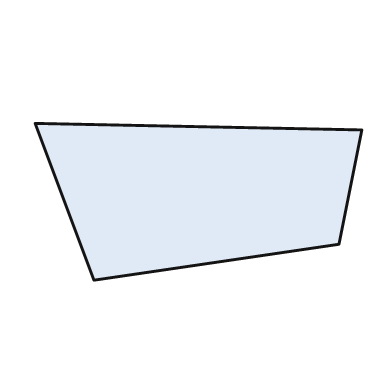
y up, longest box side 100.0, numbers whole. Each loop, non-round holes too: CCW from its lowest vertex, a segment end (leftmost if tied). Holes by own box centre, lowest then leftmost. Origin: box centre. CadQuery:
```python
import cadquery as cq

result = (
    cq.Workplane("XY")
    .moveTo(-32.0, -24.0)
    .lineTo(43.0, -13.0)
    .lineTo(50.0, 22.0)
    .lineTo(-50.0, 24.0)
    .close()
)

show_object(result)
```